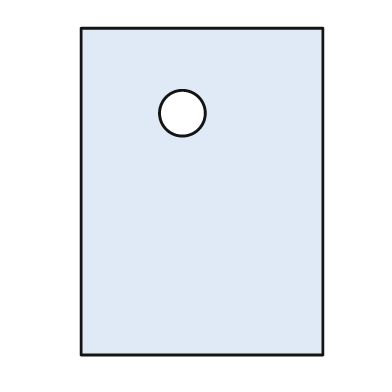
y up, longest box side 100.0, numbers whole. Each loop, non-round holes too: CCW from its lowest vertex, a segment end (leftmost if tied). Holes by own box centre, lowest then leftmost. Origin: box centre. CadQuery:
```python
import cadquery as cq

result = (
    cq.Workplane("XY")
    .moveTo(-37.0, -50.0)
    .lineTo(37.0, -50.0)
    .lineTo(37.0, 50.0)
    .lineTo(-37.0, 50.0)
    .close()
    .moveTo(-6.0, 24.0)
    .circle(7.0)
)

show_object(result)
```